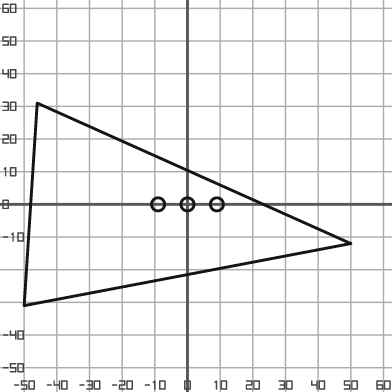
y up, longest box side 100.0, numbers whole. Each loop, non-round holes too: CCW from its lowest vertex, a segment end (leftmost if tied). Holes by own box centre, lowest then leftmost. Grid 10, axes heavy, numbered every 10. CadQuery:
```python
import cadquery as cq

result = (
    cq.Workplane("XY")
    .moveTo(-50.0, -31.0)
    .lineTo(50.0, -12.0)
    .lineTo(-46.0, 31.0)
    .close()
    .moveTo(-9.0, 0.0)
    .circle(2.0)
    .moveTo(0.0, 0.0)
    .circle(2.0)
    .moveTo(9.0, 0.0)
    .circle(2.0)
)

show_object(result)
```